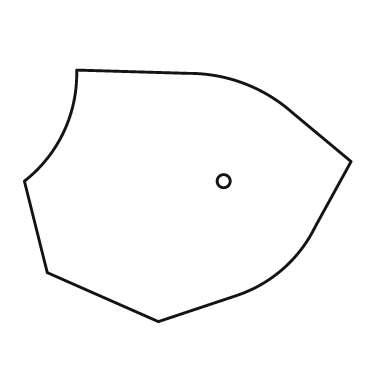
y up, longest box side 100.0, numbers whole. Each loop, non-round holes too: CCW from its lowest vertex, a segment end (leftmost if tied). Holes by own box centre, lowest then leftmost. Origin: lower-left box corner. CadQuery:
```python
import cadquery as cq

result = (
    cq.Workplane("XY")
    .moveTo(41.0, 0.0)
    .lineTo(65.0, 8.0)
    .threePointArc((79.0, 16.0), (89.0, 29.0))
    .lineTo(100.0, 49.0)
    .lineTo(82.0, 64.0)
    .threePointArc((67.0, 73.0), (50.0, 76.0))
    .lineTo(16.0, 77.0)
    .threePointArc((12.0, 58.0), (0.0, 43.0))
    .lineTo(7.0, 15.0)
    .close()
    .moveTo(61.0, 43.0)
    .circle(2.0)
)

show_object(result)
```